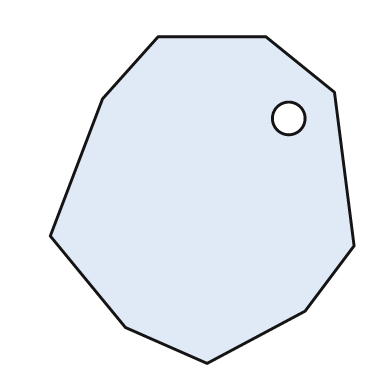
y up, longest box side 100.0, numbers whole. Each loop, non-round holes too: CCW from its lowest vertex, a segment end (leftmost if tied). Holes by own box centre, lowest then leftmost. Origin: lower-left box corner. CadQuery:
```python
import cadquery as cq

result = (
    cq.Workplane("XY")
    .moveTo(48.0, 0.0)
    .lineTo(78.0, 16.0)
    .lineTo(93.0, 36.0)
    .lineTo(87.0, 83.0)
    .lineTo(66.0, 100.0)
    .lineTo(33.0, 100.0)
    .lineTo(16.0, 81.0)
    .lineTo(0.0, 39.0)
    .lineTo(23.0, 11.0)
    .close()
    .moveTo(73.0, 75.0)
    .circle(5.0)
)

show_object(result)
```